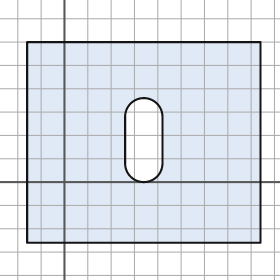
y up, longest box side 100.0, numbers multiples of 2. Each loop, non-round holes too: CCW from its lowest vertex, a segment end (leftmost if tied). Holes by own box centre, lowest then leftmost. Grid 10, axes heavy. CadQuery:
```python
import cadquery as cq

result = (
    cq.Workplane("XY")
    .moveTo(-16.0, -26.0)
    .lineTo(84.0, -26.0)
    .lineTo(84.0, 60.0)
    .lineTo(-16.0, 60.0)
    .close()
    .moveTo(26.0, 8.0)
    .threePointArc((34.0, 0.0), (42.0, 8.0))
    .lineTo(42.0, 28.0)
    .threePointArc((34.0, 36.0), (26.0, 28.0))
    .close()
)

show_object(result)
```